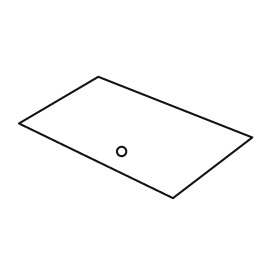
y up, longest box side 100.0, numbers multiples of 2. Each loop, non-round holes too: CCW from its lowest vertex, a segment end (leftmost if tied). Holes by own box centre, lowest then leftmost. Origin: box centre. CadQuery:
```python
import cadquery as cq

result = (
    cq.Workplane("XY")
    .moveTo(16.0, -26.0)
    .lineTo(50.0, 0.0)
    .lineTo(-16.0, 26.0)
    .lineTo(-50.0, 6.0)
    .close()
    .moveTo(-6.0, -6.0)
    .circle(2.0)
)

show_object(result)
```